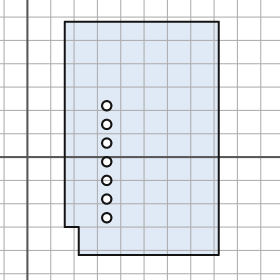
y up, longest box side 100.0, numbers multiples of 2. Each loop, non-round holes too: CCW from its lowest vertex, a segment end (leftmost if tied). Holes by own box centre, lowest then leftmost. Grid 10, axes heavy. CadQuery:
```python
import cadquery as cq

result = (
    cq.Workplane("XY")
    .moveTo(22.0, -42.0)
    .lineTo(82.0, -42.0)
    .lineTo(82.0, 58.0)
    .lineTo(16.0, 58.0)
    .lineTo(16.0, -30.0)
    .lineTo(22.0, -30.0)
    .close()
    .moveTo(34.0, -26.0)
    .circle(2.0)
    .moveTo(34.0, -18.0)
    .circle(2.0)
    .moveTo(34.0, -10.0)
    .circle(2.0)
    .moveTo(34.0, -2.0)
    .circle(2.0)
    .moveTo(34.0, 6.0)
    .circle(2.0)
    .moveTo(34.0, 14.0)
    .circle(2.0)
    .moveTo(34.0, 22.0)
    .circle(2.0)
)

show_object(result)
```